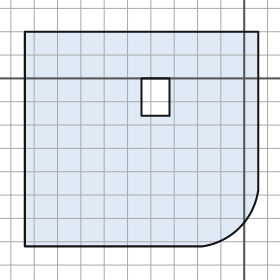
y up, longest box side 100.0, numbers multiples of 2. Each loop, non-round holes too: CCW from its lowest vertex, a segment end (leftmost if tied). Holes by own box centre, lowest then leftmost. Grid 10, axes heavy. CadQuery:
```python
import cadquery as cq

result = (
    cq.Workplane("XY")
    .moveTo(-94.0, -72.0)
    .lineTo(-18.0, -72.0)
    .threePointArc((-2.0, -64.0), (6.0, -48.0))
    .lineTo(6.0, 20.0)
    .lineTo(-94.0, 20.0)
    .close()
    .moveTo(-44.0, -16.0)
    .lineTo(-32.0, -16.0)
    .lineTo(-32.0, 0.0)
    .lineTo(-44.0, 0.0)
    .close()
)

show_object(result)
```